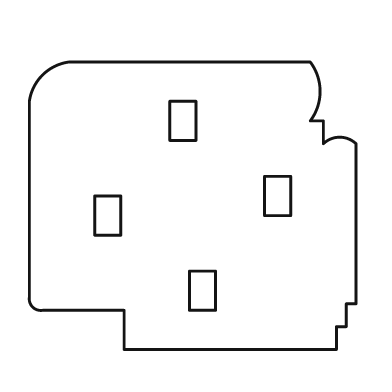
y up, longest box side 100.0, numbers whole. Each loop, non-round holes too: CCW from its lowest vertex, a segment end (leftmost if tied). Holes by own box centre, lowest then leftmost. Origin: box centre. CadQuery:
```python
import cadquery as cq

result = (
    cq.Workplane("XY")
    .moveTo(-21.0, -44.0)
    .lineTo(44.0, -44.0)
    .lineTo(44.0, -37.0)
    .lineTo(47.0, -37.0)
    .lineTo(47.0, -30.0)
    .lineTo(50.0, -30.0)
    .lineTo(50.0, 19.0)
    .threePointArc((45.0, 21.0), (40.0, 19.0))
    .lineTo(40.0, 26.0)
    .lineTo(36.0, 26.0)
    .threePointArc((39.0, 35.0), (36.0, 44.0))
    .lineTo(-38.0, 44.0)
    .threePointArc((-46.0, 40.0), (-50.0, 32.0))
    .lineTo(-50.0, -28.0)
    .threePointArc((-49.0, -31.0), (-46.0, -32.0))
    .lineTo(-21.0, -32.0)
    .close()
    .moveTo(-1.0, -32.0)
    .lineTo(7.0, -32.0)
    .lineTo(7.0, -20.0)
    .lineTo(-1.0, -20.0)
    .close()
    .moveTo(-30.0, -9.0)
    .lineTo(-22.0, -9.0)
    .lineTo(-22.0, 3.0)
    .lineTo(-30.0, 3.0)
    .close()
    .moveTo(22.0, -3.0)
    .lineTo(30.0, -3.0)
    .lineTo(30.0, 9.0)
    .lineTo(22.0, 9.0)
    .close()
    .moveTo(-7.0, 20.0)
    .lineTo(1.0, 20.0)
    .lineTo(1.0, 32.0)
    .lineTo(-7.0, 32.0)
    .close()
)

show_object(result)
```